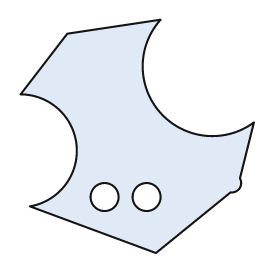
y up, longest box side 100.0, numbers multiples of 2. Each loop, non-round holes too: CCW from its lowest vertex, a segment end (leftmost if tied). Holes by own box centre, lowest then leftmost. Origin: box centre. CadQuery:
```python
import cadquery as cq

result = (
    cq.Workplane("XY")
    .moveTo(8.0, -50.0)
    .lineTo(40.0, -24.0)
    .threePointArc((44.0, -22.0), (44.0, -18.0))
    .lineTo(50.0, 6.0)
    .threePointArc((10.0, 10.0), (10.0, 50.0))
    .lineTo(-30.0, 44.0)
    .lineTo(-50.0, 18.0)
    .threePointArc((-26.0, -4.0), (-46.0, -30.0))
    .close()
    .moveTo(-14.0, -26.0)
    .circle(6.0)
    .moveTo(4.0, -26.0)
    .circle(6.0)
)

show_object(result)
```